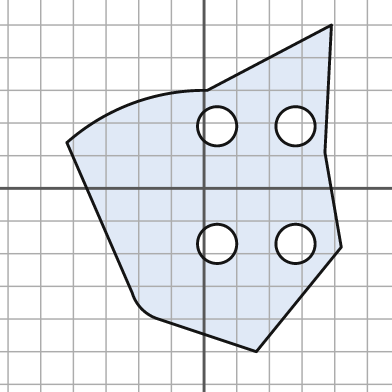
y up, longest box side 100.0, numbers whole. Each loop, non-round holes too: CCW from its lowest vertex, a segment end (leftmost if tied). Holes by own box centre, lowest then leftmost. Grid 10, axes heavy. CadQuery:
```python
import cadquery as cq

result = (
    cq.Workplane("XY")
    .moveTo(16.0, -50.0)
    .lineTo(42.0, -18.0)
    .lineTo(37.0, 11.0)
    .lineTo(39.0, 50.0)
    .lineTo(1.0, 30.0)
    .threePointArc((-22.0, 26.0), (-42.0, 14.0))
    .lineTo(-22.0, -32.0)
    .threePointArc((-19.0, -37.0), (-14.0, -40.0))
    .close()
    .moveTo(4.0, -17.0)
    .circle(6.0)
    .moveTo(28.0, -17.0)
    .circle(6.0)
    .moveTo(4.0, 19.0)
    .circle(6.0)
    .moveTo(28.0, 19.0)
    .circle(6.0)
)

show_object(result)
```